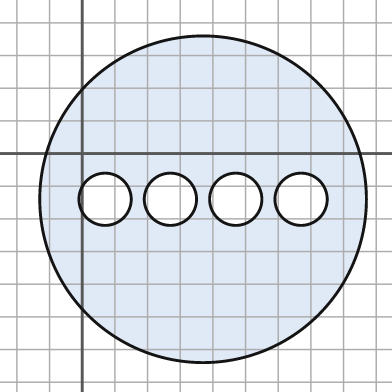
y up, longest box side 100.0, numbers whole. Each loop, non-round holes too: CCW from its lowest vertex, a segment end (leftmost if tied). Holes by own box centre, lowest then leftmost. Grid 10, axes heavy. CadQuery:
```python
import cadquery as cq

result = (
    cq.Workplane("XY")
    .moveTo(37.0, -14.0)
    .circle(50.0)
    .moveTo(7.0, -14.0)
    .circle(8.0)
    .moveTo(27.0, -14.0)
    .circle(8.0)
    .moveTo(47.0, -14.0)
    .circle(8.0)
    .moveTo(67.0, -14.0)
    .circle(8.0)
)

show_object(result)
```